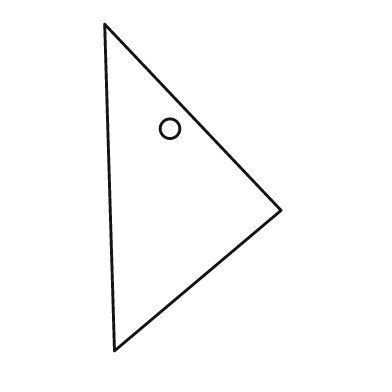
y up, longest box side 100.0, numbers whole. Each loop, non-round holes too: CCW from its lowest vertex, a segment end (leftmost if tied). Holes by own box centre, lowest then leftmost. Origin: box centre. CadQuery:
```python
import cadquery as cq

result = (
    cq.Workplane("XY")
    .moveTo(-24.0, -50.0)
    .lineTo(27.0, -7.0)
    .lineTo(-27.0, 50.0)
    .close()
    .moveTo(-7.0, 18.0)
    .circle(3.0)
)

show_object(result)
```